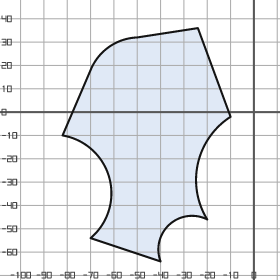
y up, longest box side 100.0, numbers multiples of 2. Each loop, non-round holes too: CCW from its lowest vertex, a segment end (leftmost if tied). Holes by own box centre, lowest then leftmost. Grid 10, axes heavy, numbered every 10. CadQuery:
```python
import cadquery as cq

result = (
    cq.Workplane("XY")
    .moveTo(-40.0, -64.0)
    .threePointArc((-36.0, -48.0), (-20.0, -46.0))
    .threePointArc((-24.0, -22.0), (-10.0, -2.0))
    .lineTo(-24.0, 36.0)
    .lineTo(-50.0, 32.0)
    .threePointArc((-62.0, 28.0), (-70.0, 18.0))
    .lineTo(-82.0, -10.0)
    .threePointArc((-62.0, -28.0), (-70.0, -54.0))
    .close()
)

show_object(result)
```